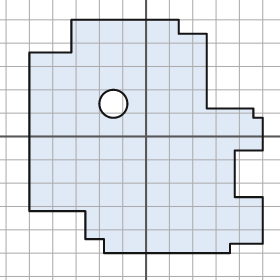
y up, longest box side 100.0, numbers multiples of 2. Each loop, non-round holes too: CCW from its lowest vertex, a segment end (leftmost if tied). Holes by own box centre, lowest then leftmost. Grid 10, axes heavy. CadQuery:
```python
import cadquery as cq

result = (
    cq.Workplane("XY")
    .moveTo(-18.0, -50.0)
    .lineTo(36.0, -50.0)
    .lineTo(36.0, -46.0)
    .lineTo(50.0, -46.0)
    .lineTo(50.0, -26.0)
    .lineTo(38.0, -26.0)
    .lineTo(38.0, -6.0)
    .lineTo(50.0, -6.0)
    .lineTo(50.0, 8.0)
    .lineTo(46.0, 8.0)
    .lineTo(46.0, 12.0)
    .lineTo(26.0, 12.0)
    .lineTo(26.0, 44.0)
    .lineTo(14.0, 44.0)
    .lineTo(14.0, 50.0)
    .lineTo(-32.0, 50.0)
    .lineTo(-32.0, 36.0)
    .lineTo(-50.0, 36.0)
    .lineTo(-50.0, -32.0)
    .lineTo(-26.0, -32.0)
    .lineTo(-26.0, -44.0)
    .lineTo(-18.0, -44.0)
    .close()
    .moveTo(-14.0, 14.0)
    .circle(6.0)
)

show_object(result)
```